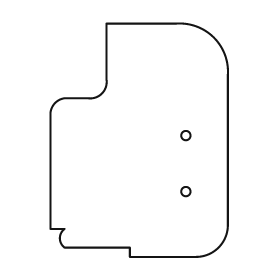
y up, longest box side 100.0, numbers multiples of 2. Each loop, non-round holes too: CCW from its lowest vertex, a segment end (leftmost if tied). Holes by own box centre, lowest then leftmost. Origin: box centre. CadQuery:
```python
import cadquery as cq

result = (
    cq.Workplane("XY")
    .moveTo(-4.0, -50.0)
    .lineTo(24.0, -50.0)
    .threePointArc((34.0, -46.0), (38.0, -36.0))
    .lineTo(38.0, 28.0)
    .threePointArc((32.0, 44.0), (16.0, 50.0))
    .lineTo(-14.0, 50.0)
    .lineTo(-14.0, 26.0)
    .threePointArc((-16.0, 20.0), (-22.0, 18.0))
    .lineTo(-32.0, 18.0)
    .threePointArc((-36.0, 16.0), (-38.0, 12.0))
    .lineTo(-38.0, -38.0)
    .lineTo(-32.0, -38.0)
    .threePointArc((-34.0, -42.0), (-32.0, -46.0))
    .lineTo(-4.0, -46.0)
    .close()
    .moveTo(20.0, -22.0)
    .circle(2.0)
    .moveTo(20.0, 2.0)
    .circle(2.0)
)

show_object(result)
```